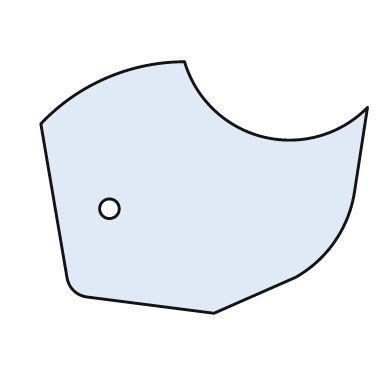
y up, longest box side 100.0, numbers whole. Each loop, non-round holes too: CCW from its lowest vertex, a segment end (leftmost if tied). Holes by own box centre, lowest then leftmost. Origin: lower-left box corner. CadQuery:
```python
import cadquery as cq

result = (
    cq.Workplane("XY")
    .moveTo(53.0, 0.0)
    .lineTo(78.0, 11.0)
    .threePointArc((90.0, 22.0), (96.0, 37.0))
    .lineTo(100.0, 63.0)
    .threePointArc((68.0, 54.0), (44.0, 77.0))
    .threePointArc((20.0, 72.0), (0.0, 58.0))
    .lineTo(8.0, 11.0)
    .threePointArc((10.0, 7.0), (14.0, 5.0))
    .close()
    .moveTo(21.0, 32.0)
    .circle(3.0)
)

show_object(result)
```